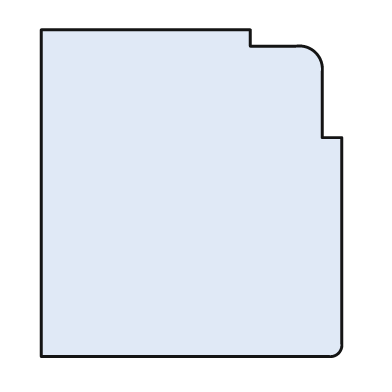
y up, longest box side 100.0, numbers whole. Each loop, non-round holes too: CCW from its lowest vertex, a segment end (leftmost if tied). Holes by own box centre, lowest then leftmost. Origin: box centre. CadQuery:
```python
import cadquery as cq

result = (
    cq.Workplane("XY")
    .moveTo(-46.0, -50.0)
    .lineTo(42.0, -50.0)
    .threePointArc((45.0, -49.0), (46.0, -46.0))
    .lineTo(46.0, 17.0)
    .lineTo(40.0, 17.0)
    .lineTo(40.0, 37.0)
    .threePointArc((38.0, 43.0), (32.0, 45.0))
    .lineTo(18.0, 45.0)
    .lineTo(18.0, 50.0)
    .lineTo(-46.0, 50.0)
    .close()
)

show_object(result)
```